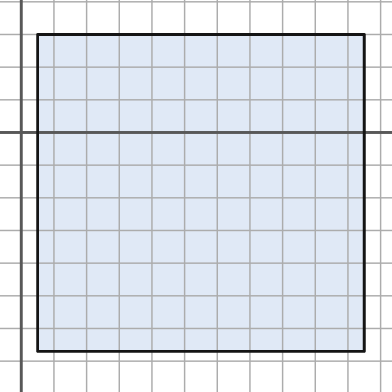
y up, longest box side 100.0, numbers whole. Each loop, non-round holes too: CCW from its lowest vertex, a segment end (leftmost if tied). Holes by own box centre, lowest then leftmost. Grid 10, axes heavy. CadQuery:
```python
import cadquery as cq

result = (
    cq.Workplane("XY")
    .moveTo(5.0, -67.0)
    .lineTo(105.0, -67.0)
    .lineTo(105.0, 30.0)
    .lineTo(5.0, 30.0)
    .close()
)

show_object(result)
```